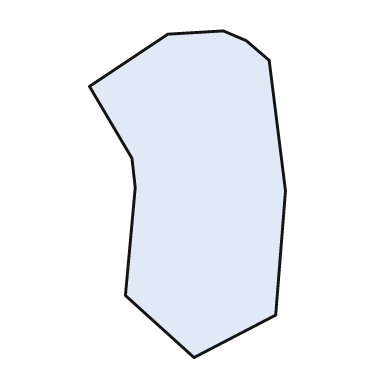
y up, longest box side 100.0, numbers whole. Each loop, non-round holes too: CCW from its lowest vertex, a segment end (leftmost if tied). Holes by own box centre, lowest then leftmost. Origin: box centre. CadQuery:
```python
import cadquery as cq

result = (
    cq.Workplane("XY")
    .moveTo(2.0, -50.0)
    .lineTo(27.0, -37.0)
    .lineTo(30.0, 1.0)
    .lineTo(25.0, 41.0)
    .lineTo(18.0, 47.0)
    .lineTo(11.0, 50.0)
    .lineTo(-6.0, 49.0)
    .lineTo(-30.0, 33.0)
    .lineTo(-17.0, 11.0)
    .lineTo(-16.0, 2.0)
    .lineTo(-19.0, -31.0)
    .close()
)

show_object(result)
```